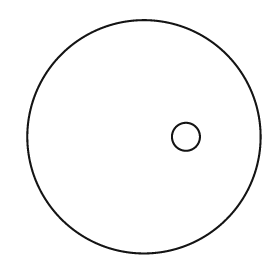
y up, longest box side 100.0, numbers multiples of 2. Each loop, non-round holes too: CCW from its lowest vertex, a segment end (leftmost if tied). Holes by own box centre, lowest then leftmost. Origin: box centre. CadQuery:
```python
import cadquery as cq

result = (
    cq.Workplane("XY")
    .moveTo(0.0, 0.0)
    .circle(50.0)
    .moveTo(18.0, 0.0)
    .circle(6.0)
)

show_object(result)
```